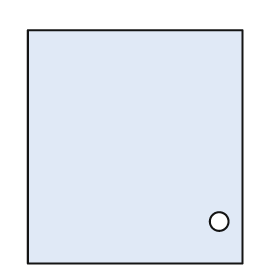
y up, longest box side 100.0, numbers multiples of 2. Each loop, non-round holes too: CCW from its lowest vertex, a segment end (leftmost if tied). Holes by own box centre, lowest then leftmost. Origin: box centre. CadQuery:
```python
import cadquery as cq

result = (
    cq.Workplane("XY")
    .moveTo(-46.0, -50.0)
    .lineTo(46.0, -50.0)
    .lineTo(46.0, 50.0)
    .lineTo(-46.0, 50.0)
    .close()
    .moveTo(36.0, -32.0)
    .circle(4.0)
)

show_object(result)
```